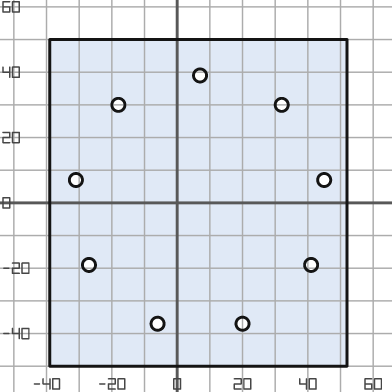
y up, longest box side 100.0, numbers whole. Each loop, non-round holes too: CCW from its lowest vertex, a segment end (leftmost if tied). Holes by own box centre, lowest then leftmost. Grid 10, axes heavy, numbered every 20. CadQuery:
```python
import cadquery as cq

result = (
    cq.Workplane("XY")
    .moveTo(-39.0, -50.0)
    .lineTo(52.0, -50.0)
    .lineTo(52.0, 50.0)
    .lineTo(-39.0, 50.0)
    .close()
    .moveTo(-6.0, -37.0)
    .circle(2.0)
    .moveTo(20.0, -37.0)
    .circle(2.0)
    .moveTo(-27.0, -19.0)
    .circle(2.0)
    .moveTo(41.0, -19.0)
    .circle(2.0)
    .moveTo(-31.0, 7.0)
    .circle(2.0)
    .moveTo(45.0, 7.0)
    .circle(2.0)
    .moveTo(-18.0, 30.0)
    .circle(2.0)
    .moveTo(32.0, 30.0)
    .circle(2.0)
    .moveTo(7.0, 39.0)
    .circle(2.0)
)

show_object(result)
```